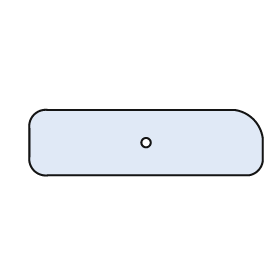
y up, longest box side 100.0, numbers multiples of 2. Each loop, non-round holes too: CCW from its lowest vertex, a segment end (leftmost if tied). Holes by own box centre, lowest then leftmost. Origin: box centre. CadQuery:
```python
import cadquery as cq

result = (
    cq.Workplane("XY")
    .moveTo(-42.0, -14.0)
    .lineTo(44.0, -14.0)
    .threePointArc((48.0, -12.0), (50.0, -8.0))
    .lineTo(50.0, 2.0)
    .threePointArc((46.0, 10.0), (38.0, 14.0))
    .lineTo(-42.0, 14.0)
    .threePointArc((-48.0, 12.0), (-50.0, 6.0))
    .lineTo(-50.0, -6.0)
    .threePointArc((-48.0, -12.0), (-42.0, -14.0))
    .close()
    .moveTo(0.0, 0.0)
    .circle(2.0)
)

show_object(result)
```